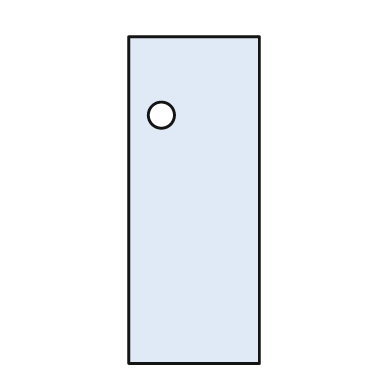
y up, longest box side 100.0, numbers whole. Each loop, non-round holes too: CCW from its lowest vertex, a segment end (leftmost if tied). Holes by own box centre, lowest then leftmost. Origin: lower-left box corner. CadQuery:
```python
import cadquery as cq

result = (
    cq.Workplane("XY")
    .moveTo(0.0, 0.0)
    .lineTo(40.0, 0.0)
    .lineTo(40.0, 100.0)
    .lineTo(0.0, 100.0)
    .close()
    .moveTo(10.0, 76.0)
    .circle(4.0)
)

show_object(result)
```